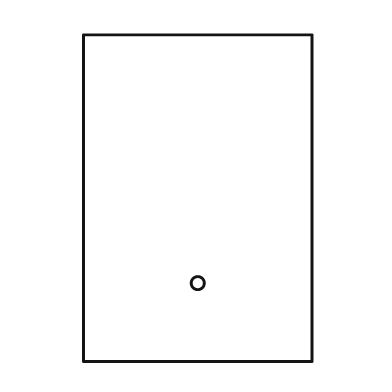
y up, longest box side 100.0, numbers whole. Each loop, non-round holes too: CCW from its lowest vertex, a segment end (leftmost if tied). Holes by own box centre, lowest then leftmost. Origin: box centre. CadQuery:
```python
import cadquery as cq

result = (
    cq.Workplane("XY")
    .moveTo(-35.0, -50.0)
    .lineTo(35.0, -50.0)
    .lineTo(35.0, 50.0)
    .lineTo(-35.0, 50.0)
    .close()
    .moveTo(0.0, -26.0)
    .circle(2.0)
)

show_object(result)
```